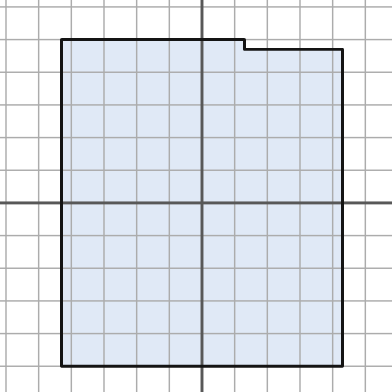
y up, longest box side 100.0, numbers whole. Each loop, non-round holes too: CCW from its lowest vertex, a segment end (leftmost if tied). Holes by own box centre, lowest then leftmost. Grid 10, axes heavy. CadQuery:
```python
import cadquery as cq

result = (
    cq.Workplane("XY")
    .moveTo(-43.0, -50.0)
    .lineTo(43.0, -50.0)
    .lineTo(43.0, 47.0)
    .lineTo(13.0, 47.0)
    .lineTo(13.0, 50.0)
    .lineTo(-43.0, 50.0)
    .close()
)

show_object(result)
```